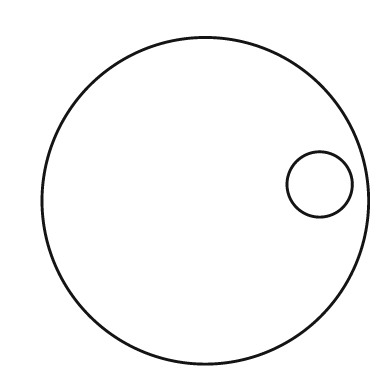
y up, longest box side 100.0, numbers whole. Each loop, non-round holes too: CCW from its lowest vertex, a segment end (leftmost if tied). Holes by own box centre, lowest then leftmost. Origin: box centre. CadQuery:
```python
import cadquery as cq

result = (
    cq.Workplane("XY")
    .moveTo(0.0, 0.0)
    .circle(50.0)
    .moveTo(35.0, 5.0)
    .circle(10.0)
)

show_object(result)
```